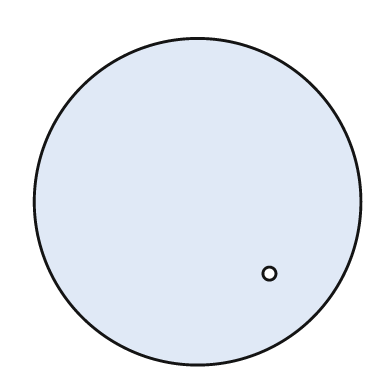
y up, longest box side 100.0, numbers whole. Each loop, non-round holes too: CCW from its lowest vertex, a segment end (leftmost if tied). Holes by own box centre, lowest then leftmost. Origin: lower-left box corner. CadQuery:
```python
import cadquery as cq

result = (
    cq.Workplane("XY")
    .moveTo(50.0, 50.0)
    .circle(50.0)
    .moveTo(72.0, 28.0)
    .circle(2.0)
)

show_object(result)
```